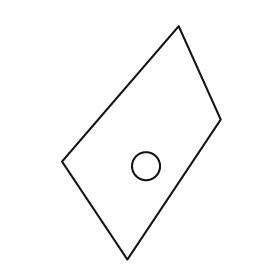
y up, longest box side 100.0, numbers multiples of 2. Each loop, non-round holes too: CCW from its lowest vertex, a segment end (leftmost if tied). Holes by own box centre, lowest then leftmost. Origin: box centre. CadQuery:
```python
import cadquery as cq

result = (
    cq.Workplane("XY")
    .moveTo(-6.0, -50.0)
    .lineTo(34.0, 10.0)
    .lineTo(16.0, 50.0)
    .lineTo(-34.0, -8.0)
    .close()
    .moveTo(2.0, -10.0)
    .circle(6.0)
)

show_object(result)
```